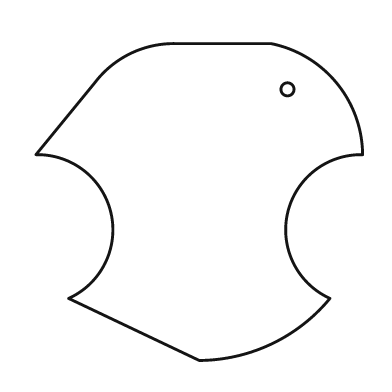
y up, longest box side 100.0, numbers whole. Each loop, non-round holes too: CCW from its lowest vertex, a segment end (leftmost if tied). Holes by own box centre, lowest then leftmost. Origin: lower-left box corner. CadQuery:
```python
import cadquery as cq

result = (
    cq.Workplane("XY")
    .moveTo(50.0, 0.0)
    .threePointArc((72.0, 5.0), (90.0, 19.0))
    .threePointArc((77.0, 45.0), (100.0, 63.0))
    .threePointArc((92.0, 85.0), (72.0, 97.0))
    .lineTo(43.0, 97.0)
    .threePointArc((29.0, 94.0), (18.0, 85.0))
    .lineTo(0.0, 63.0)
    .threePointArc((23.0, 45.0), (10.0, 19.0))
    .close()
    .moveTo(77.0, 83.0)
    .circle(2.0)
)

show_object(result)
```